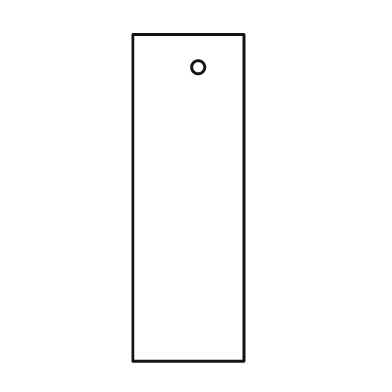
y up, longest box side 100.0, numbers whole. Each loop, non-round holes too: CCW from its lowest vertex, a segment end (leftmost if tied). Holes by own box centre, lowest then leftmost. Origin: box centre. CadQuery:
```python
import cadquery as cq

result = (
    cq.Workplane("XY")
    .moveTo(-17.0, -50.0)
    .lineTo(17.0, -50.0)
    .lineTo(17.0, 50.0)
    .lineTo(-17.0, 50.0)
    .close()
    .moveTo(3.0, 40.0)
    .circle(2.0)
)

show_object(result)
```